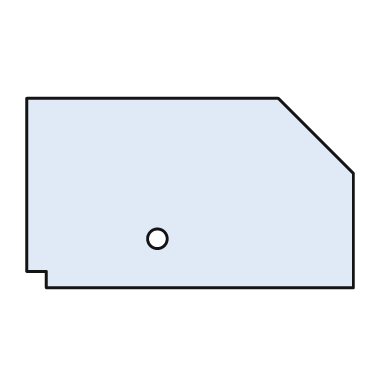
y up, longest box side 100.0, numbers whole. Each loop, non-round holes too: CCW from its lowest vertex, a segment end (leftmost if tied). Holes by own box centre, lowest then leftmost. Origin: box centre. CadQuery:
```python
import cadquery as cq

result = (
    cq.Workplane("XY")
    .moveTo(-44.0, -29.0)
    .lineTo(50.0, -29.0)
    .lineTo(50.0, 6.0)
    .lineTo(27.0, 29.0)
    .lineTo(-50.0, 29.0)
    .lineTo(-50.0, -24.0)
    .lineTo(-44.0, -24.0)
    .close()
    .moveTo(-10.0, -14.0)
    .circle(3.0)
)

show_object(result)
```